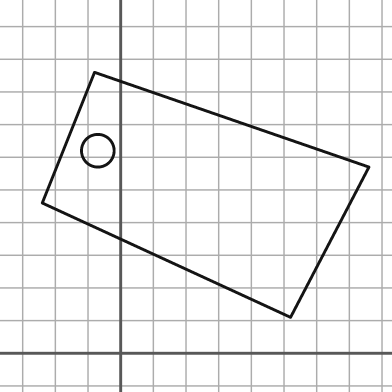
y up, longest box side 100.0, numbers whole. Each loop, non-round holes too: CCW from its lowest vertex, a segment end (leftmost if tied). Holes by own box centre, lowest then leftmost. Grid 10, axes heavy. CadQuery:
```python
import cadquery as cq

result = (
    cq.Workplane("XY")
    .moveTo(52.0, 11.0)
    .lineTo(76.0, 57.0)
    .lineTo(-8.0, 86.0)
    .lineTo(-24.0, 46.0)
    .close()
    .moveTo(-7.0, 62.0)
    .circle(5.0)
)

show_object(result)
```